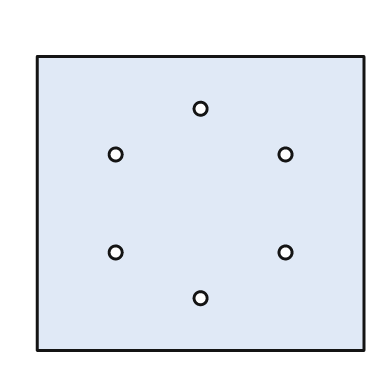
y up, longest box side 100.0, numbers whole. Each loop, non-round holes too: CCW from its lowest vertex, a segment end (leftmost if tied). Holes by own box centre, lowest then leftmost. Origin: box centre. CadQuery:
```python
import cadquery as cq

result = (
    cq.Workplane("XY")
    .moveTo(-50.0, -45.0)
    .lineTo(50.0, -45.0)
    .lineTo(50.0, 45.0)
    .lineTo(-50.0, 45.0)
    .close()
    .moveTo(0.0, -29.0)
    .circle(2.0)
    .moveTo(-26.0, -15.0)
    .circle(2.0)
    .moveTo(26.0, -15.0)
    .circle(2.0)
    .moveTo(-26.0, 15.0)
    .circle(2.0)
    .moveTo(26.0, 15.0)
    .circle(2.0)
    .moveTo(0.0, 29.0)
    .circle(2.0)
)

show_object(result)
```